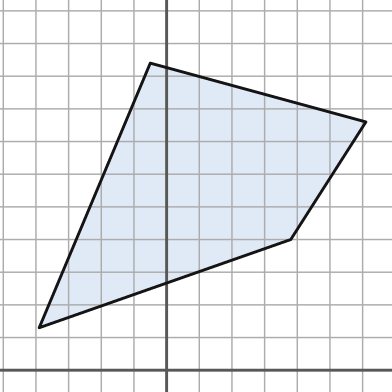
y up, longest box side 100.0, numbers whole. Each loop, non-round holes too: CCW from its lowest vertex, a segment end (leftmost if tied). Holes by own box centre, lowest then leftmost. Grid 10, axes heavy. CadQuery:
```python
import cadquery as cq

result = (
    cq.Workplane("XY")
    .moveTo(-39.0, 13.0)
    .lineTo(38.0, 40.0)
    .lineTo(61.0, 76.0)
    .lineTo(-5.0, 94.0)
    .close()
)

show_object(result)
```